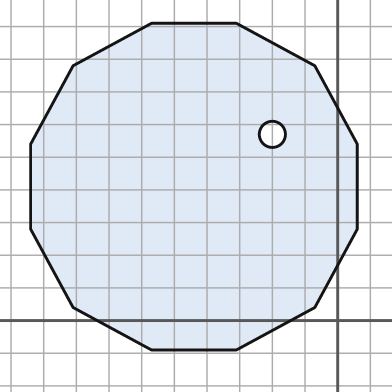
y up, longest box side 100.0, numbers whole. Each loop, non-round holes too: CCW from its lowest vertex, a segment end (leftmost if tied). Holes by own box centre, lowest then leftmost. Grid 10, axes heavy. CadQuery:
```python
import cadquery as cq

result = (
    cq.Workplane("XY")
    .moveTo(-57.0, -9.0)
    .lineTo(-31.0, -9.0)
    .lineTo(-7.0, 4.0)
    .lineTo(6.0, 28.0)
    .lineTo(6.0, 54.0)
    .lineTo(-7.0, 78.0)
    .lineTo(-31.0, 91.0)
    .lineTo(-57.0, 91.0)
    .lineTo(-81.0, 78.0)
    .lineTo(-94.0, 54.0)
    .lineTo(-94.0, 28.0)
    .lineTo(-81.0, 4.0)
    .close()
    .moveTo(-20.0, 57.0)
    .circle(4.0)
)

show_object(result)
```